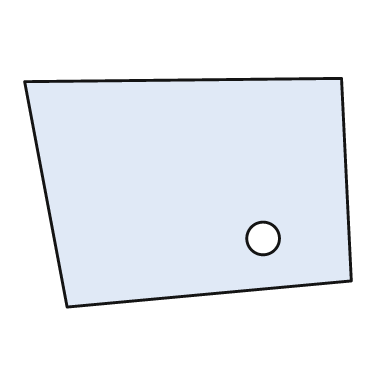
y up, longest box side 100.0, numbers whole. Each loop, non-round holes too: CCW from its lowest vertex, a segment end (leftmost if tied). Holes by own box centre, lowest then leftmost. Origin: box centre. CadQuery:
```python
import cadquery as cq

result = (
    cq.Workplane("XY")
    .moveTo(-37.0, -35.0)
    .lineTo(50.0, -27.0)
    .lineTo(47.0, 35.0)
    .lineTo(-50.0, 34.0)
    .close()
    .moveTo(23.0, -14.0)
    .circle(5.0)
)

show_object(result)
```